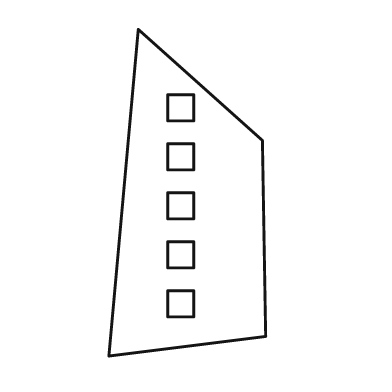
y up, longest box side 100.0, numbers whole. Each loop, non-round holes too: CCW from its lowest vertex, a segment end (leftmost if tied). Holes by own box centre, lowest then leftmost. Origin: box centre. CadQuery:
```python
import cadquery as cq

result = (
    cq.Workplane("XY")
    .moveTo(-24.0, -50.0)
    .lineTo(24.0, -44.0)
    .lineTo(23.0, 16.0)
    .lineTo(-15.0, 50.0)
    .close()
    .moveTo(-6.0, -38.0)
    .lineTo(2.0, -38.0)
    .lineTo(2.0, -30.0)
    .lineTo(-6.0, -30.0)
    .close()
    .moveTo(-6.0, -23.0)
    .lineTo(2.0, -23.0)
    .lineTo(2.0, -15.0)
    .lineTo(-6.0, -15.0)
    .close()
    .moveTo(-6.0, -8.0)
    .lineTo(2.0, -8.0)
    .lineTo(2.0, 0.0)
    .lineTo(-6.0, 0.0)
    .close()
    .moveTo(-6.0, 7.0)
    .lineTo(2.0, 7.0)
    .lineTo(2.0, 15.0)
    .lineTo(-6.0, 15.0)
    .close()
    .moveTo(-6.0, 22.0)
    .lineTo(2.0, 22.0)
    .lineTo(2.0, 30.0)
    .lineTo(-6.0, 30.0)
    .close()
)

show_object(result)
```